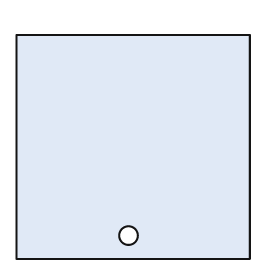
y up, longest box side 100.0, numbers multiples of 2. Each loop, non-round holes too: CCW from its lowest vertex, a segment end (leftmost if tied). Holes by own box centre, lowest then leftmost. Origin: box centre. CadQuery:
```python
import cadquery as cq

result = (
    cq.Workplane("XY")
    .moveTo(-50.0, -48.0)
    .lineTo(50.0, -48.0)
    .lineTo(50.0, 48.0)
    .lineTo(-50.0, 48.0)
    .close()
    .moveTo(-2.0, -38.0)
    .circle(4.0)
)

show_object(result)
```